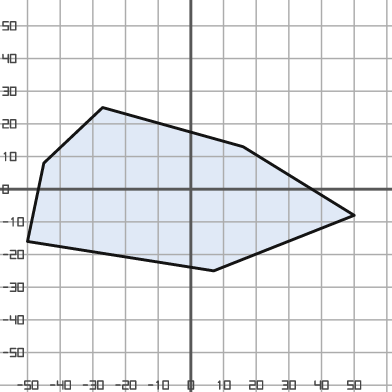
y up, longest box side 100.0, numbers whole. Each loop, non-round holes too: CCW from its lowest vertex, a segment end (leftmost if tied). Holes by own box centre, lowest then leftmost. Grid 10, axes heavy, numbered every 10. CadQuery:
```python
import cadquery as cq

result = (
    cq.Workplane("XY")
    .moveTo(7.0, -25.0)
    .lineTo(50.0, -8.0)
    .lineTo(16.0, 13.0)
    .lineTo(-27.0, 25.0)
    .lineTo(-45.0, 8.0)
    .lineTo(-50.0, -16.0)
    .close()
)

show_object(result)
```